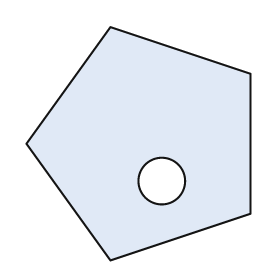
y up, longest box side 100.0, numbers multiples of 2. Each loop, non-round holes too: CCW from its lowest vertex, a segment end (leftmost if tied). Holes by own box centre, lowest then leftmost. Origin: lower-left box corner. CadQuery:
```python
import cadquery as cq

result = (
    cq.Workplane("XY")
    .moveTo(36.0, 0.0)
    .lineTo(96.0, 20.0)
    .lineTo(96.0, 80.0)
    .lineTo(36.0, 100.0)
    .lineTo(0.0, 50.0)
    .close()
    .moveTo(58.0, 34.0)
    .circle(10.0)
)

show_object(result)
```